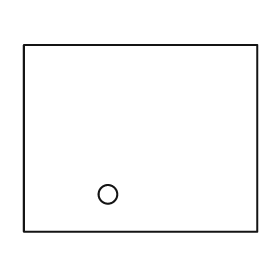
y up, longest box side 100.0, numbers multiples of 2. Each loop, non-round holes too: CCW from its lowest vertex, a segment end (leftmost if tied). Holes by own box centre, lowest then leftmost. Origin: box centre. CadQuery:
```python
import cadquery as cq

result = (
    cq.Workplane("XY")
    .moveTo(-50.0, -40.0)
    .lineTo(50.0, -40.0)
    .lineTo(50.0, 40.0)
    .lineTo(-50.0, 40.0)
    .close()
    .moveTo(-14.0, -24.0)
    .circle(4.0)
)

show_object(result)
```